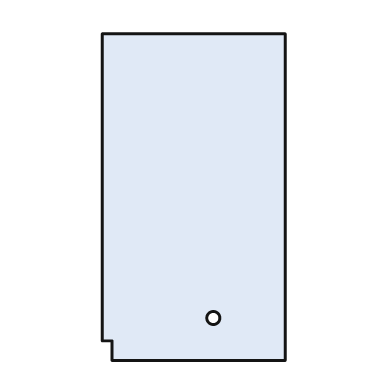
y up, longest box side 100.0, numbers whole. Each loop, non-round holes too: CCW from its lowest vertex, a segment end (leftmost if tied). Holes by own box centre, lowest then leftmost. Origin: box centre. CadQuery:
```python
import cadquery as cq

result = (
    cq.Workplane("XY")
    .moveTo(-25.0, -50.0)
    .lineTo(28.0, -50.0)
    .lineTo(28.0, 50.0)
    .lineTo(-28.0, 50.0)
    .lineTo(-28.0, -44.0)
    .lineTo(-25.0, -44.0)
    .close()
    .moveTo(6.0, -37.0)
    .circle(2.0)
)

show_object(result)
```